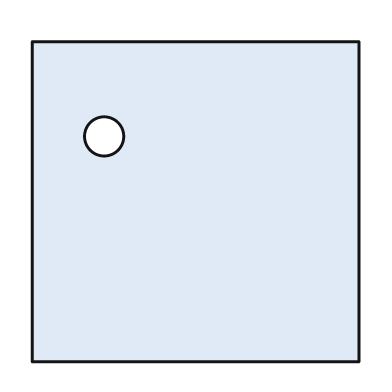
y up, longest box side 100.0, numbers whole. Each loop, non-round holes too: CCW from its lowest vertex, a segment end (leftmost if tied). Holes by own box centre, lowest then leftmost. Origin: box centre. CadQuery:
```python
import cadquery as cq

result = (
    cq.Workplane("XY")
    .moveTo(-50.0, -49.0)
    .lineTo(50.0, -49.0)
    .lineTo(50.0, 49.0)
    .lineTo(-50.0, 49.0)
    .close()
    .moveTo(-28.0, 20.0)
    .circle(6.0)
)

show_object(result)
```